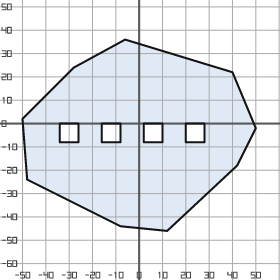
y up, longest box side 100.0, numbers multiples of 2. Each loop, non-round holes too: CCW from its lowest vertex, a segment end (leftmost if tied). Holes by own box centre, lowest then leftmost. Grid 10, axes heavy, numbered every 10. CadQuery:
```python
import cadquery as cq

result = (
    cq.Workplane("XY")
    .moveTo(12.0, -46.0)
    .lineTo(42.0, -18.0)
    .lineTo(50.0, -2.0)
    .lineTo(40.0, 22.0)
    .lineTo(-6.0, 36.0)
    .lineTo(-28.0, 24.0)
    .lineTo(-50.0, 2.0)
    .lineTo(-48.0, -24.0)
    .lineTo(-8.0, -44.0)
    .close()
    .moveTo(-34.0, -8.0)
    .lineTo(-26.0, -8.0)
    .lineTo(-26.0, 0.0)
    .lineTo(-34.0, 0.0)
    .close()
    .moveTo(-16.0, -8.0)
    .lineTo(-8.0, -8.0)
    .lineTo(-8.0, 0.0)
    .lineTo(-16.0, 0.0)
    .close()
    .moveTo(2.0, -8.0)
    .lineTo(10.0, -8.0)
    .lineTo(10.0, 0.0)
    .lineTo(2.0, 0.0)
    .close()
    .moveTo(20.0, -8.0)
    .lineTo(28.0, -8.0)
    .lineTo(28.0, 0.0)
    .lineTo(20.0, 0.0)
    .close()
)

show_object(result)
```